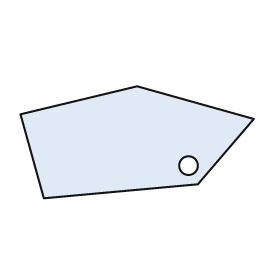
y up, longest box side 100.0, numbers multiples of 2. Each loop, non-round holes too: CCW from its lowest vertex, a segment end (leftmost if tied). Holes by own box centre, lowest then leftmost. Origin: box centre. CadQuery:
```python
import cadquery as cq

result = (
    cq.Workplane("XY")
    .moveTo(-40.0, -24.0)
    .lineTo(26.0, -18.0)
    .lineTo(50.0, 10.0)
    .lineTo(0.0, 24.0)
    .lineTo(-50.0, 12.0)
    .close()
    .moveTo(22.0, -10.0)
    .circle(4.0)
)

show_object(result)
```